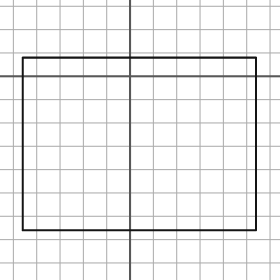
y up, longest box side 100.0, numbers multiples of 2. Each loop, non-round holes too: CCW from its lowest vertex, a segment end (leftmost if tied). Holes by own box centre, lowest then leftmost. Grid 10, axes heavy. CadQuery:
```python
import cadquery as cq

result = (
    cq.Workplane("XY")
    .moveTo(-46.0, -66.0)
    .lineTo(54.0, -66.0)
    .lineTo(54.0, 8.0)
    .lineTo(-46.0, 8.0)
    .close()
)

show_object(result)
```